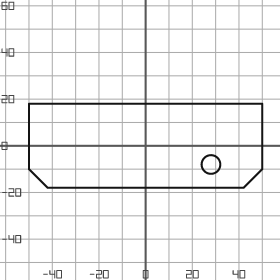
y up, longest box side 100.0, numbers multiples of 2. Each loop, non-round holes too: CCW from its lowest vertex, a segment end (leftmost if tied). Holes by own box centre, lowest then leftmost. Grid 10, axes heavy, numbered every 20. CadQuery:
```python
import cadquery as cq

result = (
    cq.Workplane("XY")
    .moveTo(-42.0, -18.0)
    .lineTo(42.0, -18.0)
    .lineTo(50.0, -10.0)
    .lineTo(50.0, 18.0)
    .lineTo(-50.0, 18.0)
    .lineTo(-50.0, -10.0)
    .close()
    .moveTo(28.0, -8.0)
    .circle(4.0)
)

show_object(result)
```